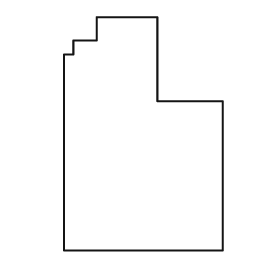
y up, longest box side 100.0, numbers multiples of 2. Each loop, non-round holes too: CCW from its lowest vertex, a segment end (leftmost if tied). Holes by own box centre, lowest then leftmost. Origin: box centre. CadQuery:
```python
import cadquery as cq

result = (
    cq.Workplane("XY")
    .moveTo(-34.0, -50.0)
    .lineTo(34.0, -50.0)
    .lineTo(34.0, 14.0)
    .lineTo(6.0, 14.0)
    .lineTo(6.0, 50.0)
    .lineTo(-20.0, 50.0)
    .lineTo(-20.0, 40.0)
    .lineTo(-30.0, 40.0)
    .lineTo(-30.0, 34.0)
    .lineTo(-34.0, 34.0)
    .close()
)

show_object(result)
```